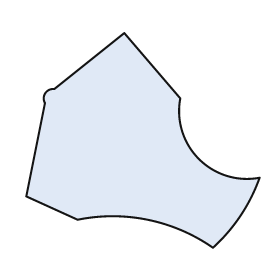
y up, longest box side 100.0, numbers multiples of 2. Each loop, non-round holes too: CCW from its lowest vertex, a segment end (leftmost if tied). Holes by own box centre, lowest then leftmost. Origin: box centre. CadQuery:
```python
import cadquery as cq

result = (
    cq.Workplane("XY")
    .moveTo(30.0, -46.0)
    .threePointArc((42.0, -32.0), (50.0, -16.0))
    .threePointArc((24.0, -8.0), (16.0, 18.0))
    .lineTo(-8.0, 46.0)
    .lineTo(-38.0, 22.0)
    .threePointArc((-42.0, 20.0), (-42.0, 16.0))
    .lineTo(-50.0, -24.0)
    .lineTo(-28.0, -34.0)
    .threePointArc((2.0, -34.0), (30.0, -46.0))
    .close()
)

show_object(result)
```